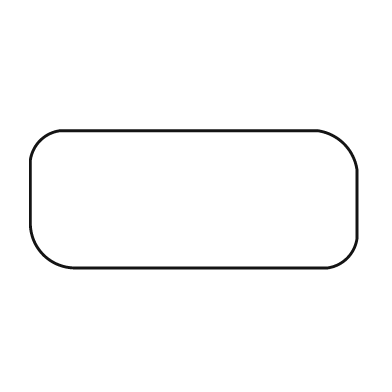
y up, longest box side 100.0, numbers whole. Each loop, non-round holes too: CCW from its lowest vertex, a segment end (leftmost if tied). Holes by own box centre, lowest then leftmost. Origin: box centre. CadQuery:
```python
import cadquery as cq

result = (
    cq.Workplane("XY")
    .moveTo(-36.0, -21.0)
    .lineTo(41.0, -21.0)
    .threePointArc((47.0, -18.0), (50.0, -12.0))
    .lineTo(50.0, 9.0)
    .threePointArc((46.0, 17.0), (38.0, 21.0))
    .lineTo(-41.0, 21.0)
    .threePointArc((-47.0, 18.0), (-50.0, 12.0))
    .lineTo(-50.0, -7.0)
    .threePointArc((-46.0, -17.0), (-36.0, -21.0))
    .close()
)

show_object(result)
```